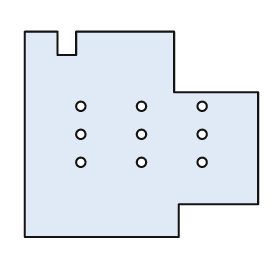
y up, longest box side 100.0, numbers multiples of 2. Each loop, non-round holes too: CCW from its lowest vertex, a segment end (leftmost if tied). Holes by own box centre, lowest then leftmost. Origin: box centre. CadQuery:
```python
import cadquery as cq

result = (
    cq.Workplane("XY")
    .moveTo(-50.0, -44.0)
    .lineTo(16.0, -44.0)
    .lineTo(16.0, -30.0)
    .lineTo(50.0, -30.0)
    .lineTo(50.0, 18.0)
    .lineTo(14.0, 18.0)
    .lineTo(14.0, 44.0)
    .lineTo(-28.0, 44.0)
    .lineTo(-28.0, 34.0)
    .lineTo(-36.0, 34.0)
    .lineTo(-36.0, 44.0)
    .lineTo(-50.0, 44.0)
    .close()
    .moveTo(-26.0, -12.0)
    .circle(2.0)
    .moveTo(0.0, -12.0)
    .circle(2.0)
    .moveTo(26.0, -12.0)
    .circle(2.0)
    .moveTo(-26.0, 0.0)
    .circle(2.0)
    .moveTo(0.0, 0.0)
    .circle(2.0)
    .moveTo(26.0, 0.0)
    .circle(2.0)
    .moveTo(-26.0, 12.0)
    .circle(2.0)
    .moveTo(0.0, 12.0)
    .circle(2.0)
    .moveTo(26.0, 12.0)
    .circle(2.0)
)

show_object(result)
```